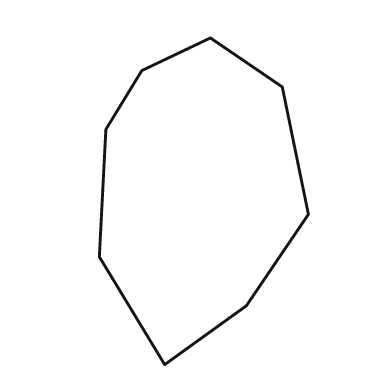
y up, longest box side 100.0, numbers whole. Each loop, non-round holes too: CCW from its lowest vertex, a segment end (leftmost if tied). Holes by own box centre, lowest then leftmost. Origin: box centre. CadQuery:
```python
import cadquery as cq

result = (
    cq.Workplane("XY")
    .moveTo(-12.0, -50.0)
    .lineTo(13.0, -32.0)
    .lineTo(32.0, -4.0)
    .lineTo(24.0, 35.0)
    .lineTo(2.0, 50.0)
    .lineTo(-19.0, 40.0)
    .lineTo(-30.0, 22.0)
    .lineTo(-32.0, -17.0)
    .close()
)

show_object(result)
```